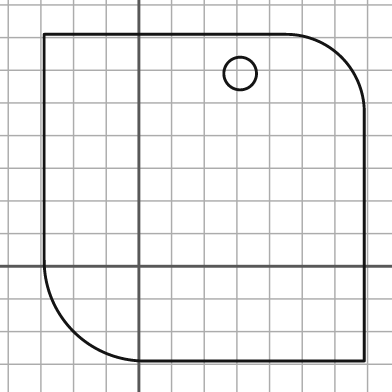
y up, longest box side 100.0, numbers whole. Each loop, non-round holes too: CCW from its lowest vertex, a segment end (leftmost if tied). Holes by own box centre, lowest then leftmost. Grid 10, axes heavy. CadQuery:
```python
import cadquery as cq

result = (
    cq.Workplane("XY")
    .moveTo(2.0, -29.0)
    .lineTo(69.0, -29.0)
    .lineTo(69.0, 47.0)
    .threePointArc((62.0, 64.0), (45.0, 71.0))
    .lineTo(-29.0, 71.0)
    .lineTo(-29.0, 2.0)
    .threePointArc((-20.0, -20.0), (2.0, -29.0))
    .close()
    .moveTo(31.0, 59.0)
    .circle(5.0)
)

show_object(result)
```